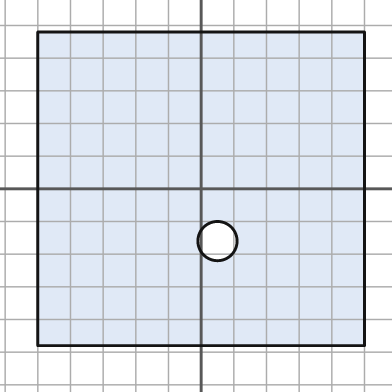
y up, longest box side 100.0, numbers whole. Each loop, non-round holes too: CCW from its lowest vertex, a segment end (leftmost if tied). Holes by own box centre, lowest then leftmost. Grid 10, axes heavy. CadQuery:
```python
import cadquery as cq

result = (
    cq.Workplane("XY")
    .moveTo(-50.0, -48.0)
    .lineTo(50.0, -48.0)
    .lineTo(50.0, 48.0)
    .lineTo(-50.0, 48.0)
    .close()
    .moveTo(5.0, -16.0)
    .circle(6.0)
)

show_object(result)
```